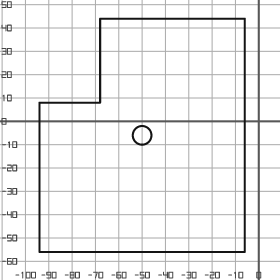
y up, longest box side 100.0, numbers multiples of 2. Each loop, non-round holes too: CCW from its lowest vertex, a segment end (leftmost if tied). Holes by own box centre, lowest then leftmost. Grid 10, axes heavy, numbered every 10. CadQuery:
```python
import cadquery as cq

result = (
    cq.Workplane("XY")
    .moveTo(-94.0, -56.0)
    .lineTo(-6.0, -56.0)
    .lineTo(-6.0, 44.0)
    .lineTo(-68.0, 44.0)
    .lineTo(-68.0, 8.0)
    .lineTo(-94.0, 8.0)
    .close()
    .moveTo(-50.0, -6.0)
    .circle(4.0)
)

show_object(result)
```